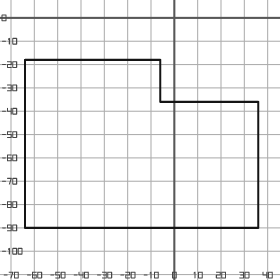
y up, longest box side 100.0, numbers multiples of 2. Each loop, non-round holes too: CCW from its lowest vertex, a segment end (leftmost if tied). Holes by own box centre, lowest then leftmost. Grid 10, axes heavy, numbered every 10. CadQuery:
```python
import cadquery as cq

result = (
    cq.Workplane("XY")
    .moveTo(-64.0, -90.0)
    .lineTo(36.0, -90.0)
    .lineTo(36.0, -36.0)
    .lineTo(-6.0, -36.0)
    .lineTo(-6.0, -18.0)
    .lineTo(-64.0, -18.0)
    .close()
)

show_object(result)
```